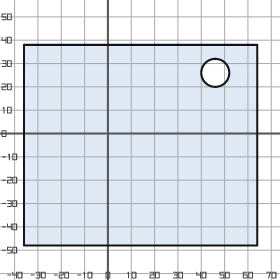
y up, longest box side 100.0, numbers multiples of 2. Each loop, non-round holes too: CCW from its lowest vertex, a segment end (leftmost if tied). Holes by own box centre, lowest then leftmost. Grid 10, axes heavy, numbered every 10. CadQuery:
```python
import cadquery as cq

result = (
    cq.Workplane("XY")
    .moveTo(-36.0, -48.0)
    .lineTo(64.0, -48.0)
    .lineTo(64.0, 38.0)
    .lineTo(-36.0, 38.0)
    .close()
    .moveTo(46.0, 26.0)
    .circle(6.0)
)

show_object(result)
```